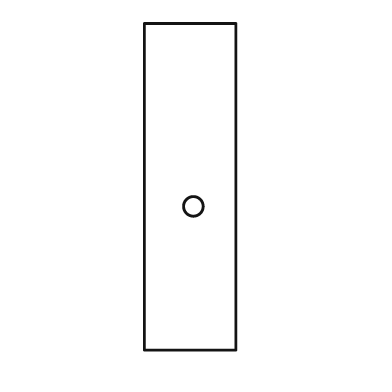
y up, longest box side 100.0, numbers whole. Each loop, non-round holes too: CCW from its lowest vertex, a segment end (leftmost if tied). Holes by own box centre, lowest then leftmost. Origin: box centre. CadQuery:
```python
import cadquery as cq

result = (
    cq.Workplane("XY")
    .moveTo(-14.0, -50.0)
    .lineTo(14.0, -50.0)
    .lineTo(14.0, 50.0)
    .lineTo(-14.0, 50.0)
    .close()
    .moveTo(1.0, -6.0)
    .circle(3.0)
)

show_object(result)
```